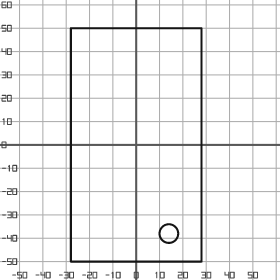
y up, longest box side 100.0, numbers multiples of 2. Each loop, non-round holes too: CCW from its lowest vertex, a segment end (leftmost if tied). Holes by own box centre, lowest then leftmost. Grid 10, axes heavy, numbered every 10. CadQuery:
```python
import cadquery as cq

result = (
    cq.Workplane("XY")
    .moveTo(-28.0, -50.0)
    .lineTo(28.0, -50.0)
    .lineTo(28.0, 50.0)
    .lineTo(-28.0, 50.0)
    .close()
    .moveTo(14.0, -38.0)
    .circle(4.0)
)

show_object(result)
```